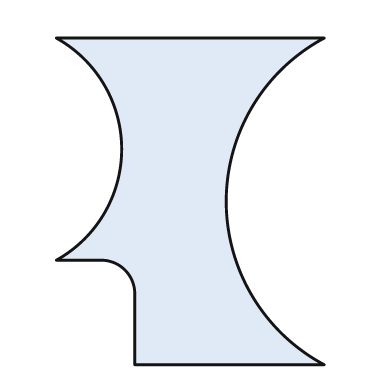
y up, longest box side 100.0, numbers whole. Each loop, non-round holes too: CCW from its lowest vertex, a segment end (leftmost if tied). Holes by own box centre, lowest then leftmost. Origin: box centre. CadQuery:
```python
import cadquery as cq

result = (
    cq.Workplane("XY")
    .moveTo(-17.0, -50.0)
    .lineTo(41.0, -50.0)
    .threePointArc((11.0, 0.0), (41.0, 50.0))
    .lineTo(-41.0, 50.0)
    .threePointArc((-21.0, 16.0), (-41.0, -18.0))
    .lineTo(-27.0, -18.0)
    .threePointArc((-20.0, -21.0), (-17.0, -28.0))
    .close()
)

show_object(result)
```